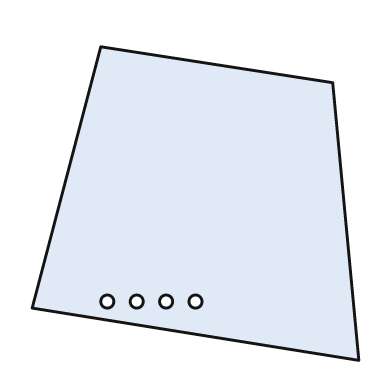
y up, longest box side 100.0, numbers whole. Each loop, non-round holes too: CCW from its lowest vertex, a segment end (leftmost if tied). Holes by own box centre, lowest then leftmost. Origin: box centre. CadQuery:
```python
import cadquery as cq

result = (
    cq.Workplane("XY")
    .moveTo(50.0, -48.0)
    .lineTo(42.0, 37.0)
    .lineTo(-29.0, 48.0)
    .lineTo(-50.0, -32.0)
    .close()
    .moveTo(-27.0, -30.0)
    .circle(2.0)
    .moveTo(-18.0, -30.0)
    .circle(2.0)
    .moveTo(-9.0, -30.0)
    .circle(2.0)
    .moveTo(0.0, -30.0)
    .circle(2.0)
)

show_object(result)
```